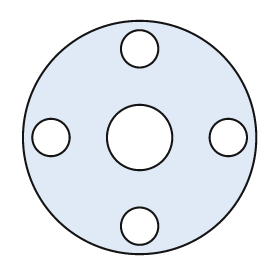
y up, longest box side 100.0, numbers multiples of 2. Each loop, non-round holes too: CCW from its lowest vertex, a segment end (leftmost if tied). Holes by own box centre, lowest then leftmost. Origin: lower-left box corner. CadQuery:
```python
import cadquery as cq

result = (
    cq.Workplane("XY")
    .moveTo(50.0, 50.0)
    .circle(50.0)
    .moveTo(50.0, 12.0)
    .circle(8.0)
    .moveTo(12.0, 50.0)
    .circle(8.0)
    .moveTo(50.0, 50.0)
    .circle(14.0)
    .moveTo(88.0, 50.0)
    .circle(8.0)
    .moveTo(50.0, 88.0)
    .circle(8.0)
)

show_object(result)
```